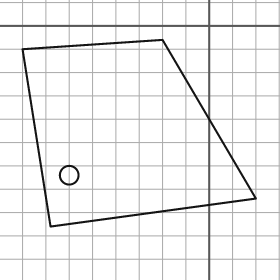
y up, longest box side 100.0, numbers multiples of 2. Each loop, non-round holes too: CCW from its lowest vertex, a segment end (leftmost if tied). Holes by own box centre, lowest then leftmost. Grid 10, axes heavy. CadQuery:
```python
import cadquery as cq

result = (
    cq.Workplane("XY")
    .moveTo(-68.0, -86.0)
    .lineTo(20.0, -74.0)
    .lineTo(-20.0, -6.0)
    .lineTo(-80.0, -10.0)
    .close()
    .moveTo(-60.0, -64.0)
    .circle(4.0)
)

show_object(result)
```